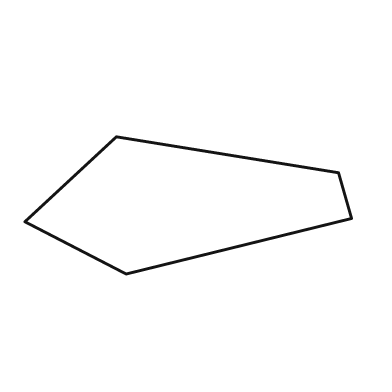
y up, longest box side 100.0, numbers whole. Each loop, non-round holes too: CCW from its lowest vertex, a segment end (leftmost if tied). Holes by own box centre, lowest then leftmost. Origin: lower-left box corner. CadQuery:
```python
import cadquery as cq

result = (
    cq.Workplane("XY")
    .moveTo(31.0, 0.0)
    .lineTo(100.0, 17.0)
    .lineTo(96.0, 31.0)
    .lineTo(28.0, 42.0)
    .lineTo(0.0, 16.0)
    .close()
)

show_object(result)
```